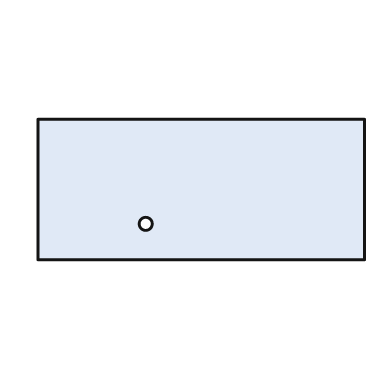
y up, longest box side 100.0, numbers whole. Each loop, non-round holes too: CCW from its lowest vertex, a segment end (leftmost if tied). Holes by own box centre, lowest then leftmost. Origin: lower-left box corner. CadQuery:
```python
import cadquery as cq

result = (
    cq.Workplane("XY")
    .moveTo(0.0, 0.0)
    .lineTo(100.0, 0.0)
    .lineTo(100.0, 43.0)
    .lineTo(0.0, 43.0)
    .close()
    .moveTo(33.0, 11.0)
    .circle(2.0)
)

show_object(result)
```